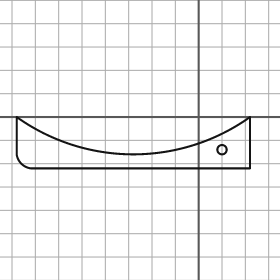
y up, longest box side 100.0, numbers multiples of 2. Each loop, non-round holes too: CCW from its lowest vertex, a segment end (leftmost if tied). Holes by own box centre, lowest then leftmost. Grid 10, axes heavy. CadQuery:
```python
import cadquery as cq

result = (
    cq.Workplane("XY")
    .moveTo(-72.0, -22.0)
    .lineTo(22.0, -22.0)
    .lineTo(22.0, 0.0)
    .threePointArc((-28.0, -16.0), (-78.0, 0.0))
    .lineTo(-78.0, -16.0)
    .threePointArc((-76.0, -20.0), (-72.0, -22.0))
    .close()
    .moveTo(10.0, -14.0)
    .circle(2.0)
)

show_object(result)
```